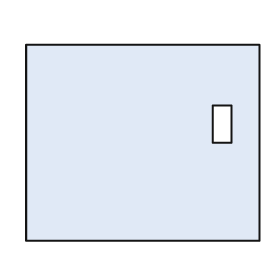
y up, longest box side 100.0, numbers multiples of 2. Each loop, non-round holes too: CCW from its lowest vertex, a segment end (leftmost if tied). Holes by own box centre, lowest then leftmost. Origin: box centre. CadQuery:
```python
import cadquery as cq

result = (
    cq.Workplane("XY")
    .moveTo(-50.0, -42.0)
    .lineTo(50.0, -42.0)
    .lineTo(50.0, 42.0)
    .lineTo(-50.0, 42.0)
    .close()
    .moveTo(30.0, 0.0)
    .lineTo(38.0, 0.0)
    .lineTo(38.0, 16.0)
    .lineTo(30.0, 16.0)
    .close()
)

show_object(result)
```